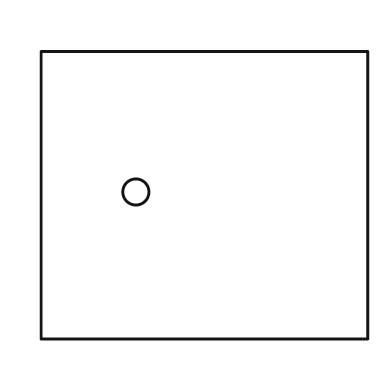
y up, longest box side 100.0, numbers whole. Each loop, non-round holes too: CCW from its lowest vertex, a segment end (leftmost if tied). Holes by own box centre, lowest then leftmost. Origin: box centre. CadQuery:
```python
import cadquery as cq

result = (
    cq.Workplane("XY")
    .moveTo(-50.0, -44.0)
    .lineTo(50.0, -44.0)
    .lineTo(50.0, 44.0)
    .lineTo(-50.0, 44.0)
    .close()
    .moveTo(-21.0, 1.0)
    .circle(4.0)
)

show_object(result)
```